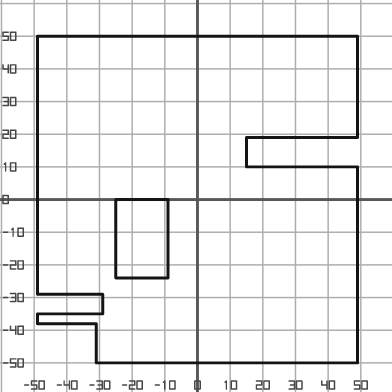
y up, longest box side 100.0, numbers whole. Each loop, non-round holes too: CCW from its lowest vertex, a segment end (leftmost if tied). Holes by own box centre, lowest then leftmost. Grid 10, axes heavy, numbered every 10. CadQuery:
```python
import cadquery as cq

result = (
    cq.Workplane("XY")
    .moveTo(-31.0, -50.0)
    .lineTo(49.0, -50.0)
    .lineTo(49.0, 10.0)
    .lineTo(15.0, 10.0)
    .lineTo(15.0, 19.0)
    .lineTo(49.0, 19.0)
    .lineTo(49.0, 50.0)
    .lineTo(-49.0, 50.0)
    .lineTo(-49.0, -29.0)
    .lineTo(-29.0, -29.0)
    .lineTo(-29.0, -35.0)
    .lineTo(-49.0, -35.0)
    .lineTo(-49.0, -38.0)
    .lineTo(-31.0, -38.0)
    .close()
    .moveTo(-25.0, -24.0)
    .lineTo(-9.0, -24.0)
    .lineTo(-9.0, 0.0)
    .lineTo(-25.0, 0.0)
    .close()
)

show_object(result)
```